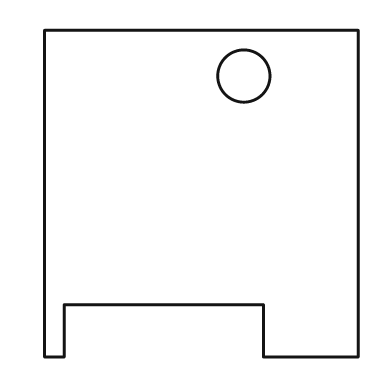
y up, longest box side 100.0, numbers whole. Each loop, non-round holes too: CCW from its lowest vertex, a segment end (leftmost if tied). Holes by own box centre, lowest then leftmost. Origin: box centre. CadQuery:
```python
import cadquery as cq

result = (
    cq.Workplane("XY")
    .moveTo(-48.0, -50.0)
    .lineTo(-42.0, -50.0)
    .lineTo(-42.0, -34.0)
    .lineTo(19.0, -34.0)
    .lineTo(19.0, -50.0)
    .lineTo(48.0, -50.0)
    .lineTo(48.0, 50.0)
    .lineTo(-48.0, 50.0)
    .close()
    .moveTo(13.0, 36.0)
    .circle(8.0)
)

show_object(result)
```